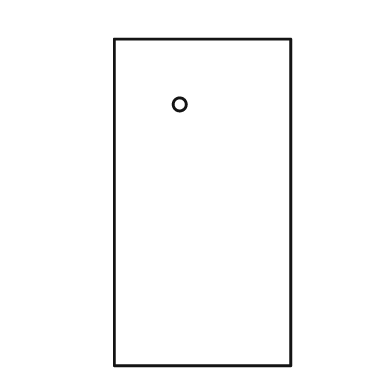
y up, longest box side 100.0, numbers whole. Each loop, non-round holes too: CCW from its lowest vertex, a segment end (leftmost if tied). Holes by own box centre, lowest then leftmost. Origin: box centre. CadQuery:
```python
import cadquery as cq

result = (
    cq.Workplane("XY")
    .moveTo(-27.0, -50.0)
    .lineTo(27.0, -50.0)
    .lineTo(27.0, 50.0)
    .lineTo(-27.0, 50.0)
    .close()
    .moveTo(-7.0, 30.0)
    .circle(2.0)
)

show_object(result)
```